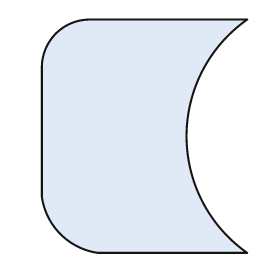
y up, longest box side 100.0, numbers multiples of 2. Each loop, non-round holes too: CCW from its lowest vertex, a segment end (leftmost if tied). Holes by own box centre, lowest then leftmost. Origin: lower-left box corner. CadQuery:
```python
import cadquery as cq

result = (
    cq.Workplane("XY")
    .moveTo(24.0, 0.0)
    .lineTo(88.0, 0.0)
    .threePointArc((62.0, 50.0), (88.0, 100.0))
    .lineTo(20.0, 100.0)
    .threePointArc((6.0, 94.0), (0.0, 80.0))
    .lineTo(0.0, 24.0)
    .threePointArc((8.0, 8.0), (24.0, 0.0))
    .close()
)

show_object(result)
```